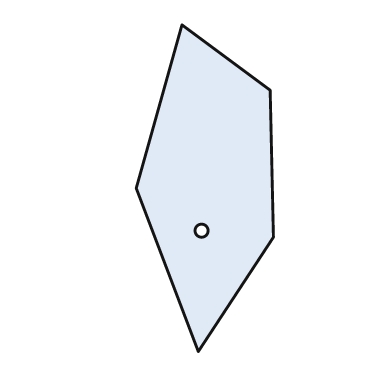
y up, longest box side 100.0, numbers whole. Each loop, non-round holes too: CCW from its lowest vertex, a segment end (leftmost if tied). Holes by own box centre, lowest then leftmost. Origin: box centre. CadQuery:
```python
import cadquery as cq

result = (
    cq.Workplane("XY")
    .moveTo(-2.0, -50.0)
    .lineTo(21.0, -15.0)
    .lineTo(20.0, 30.0)
    .lineTo(-7.0, 50.0)
    .lineTo(-21.0, 0.0)
    .close()
    .moveTo(-1.0, -13.0)
    .circle(2.0)
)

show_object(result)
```